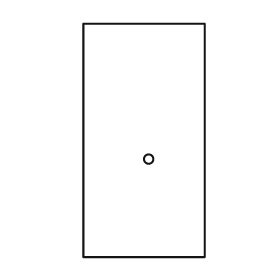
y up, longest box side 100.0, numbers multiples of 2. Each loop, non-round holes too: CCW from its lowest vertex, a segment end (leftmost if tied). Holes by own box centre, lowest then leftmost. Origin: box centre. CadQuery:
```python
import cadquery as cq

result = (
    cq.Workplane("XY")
    .moveTo(-26.0, -50.0)
    .lineTo(26.0, -50.0)
    .lineTo(26.0, 50.0)
    .lineTo(-26.0, 50.0)
    .close()
    .moveTo(2.0, -8.0)
    .circle(2.0)
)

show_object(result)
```